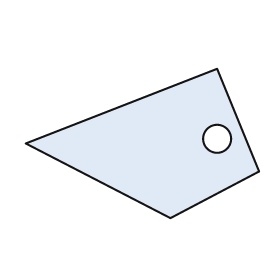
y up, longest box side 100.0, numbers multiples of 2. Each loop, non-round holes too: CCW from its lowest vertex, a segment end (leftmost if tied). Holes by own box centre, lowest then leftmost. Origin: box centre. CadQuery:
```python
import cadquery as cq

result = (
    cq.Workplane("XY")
    .moveTo(12.0, -32.0)
    .lineTo(50.0, -12.0)
    .lineTo(32.0, 32.0)
    .lineTo(-50.0, 0.0)
    .close()
    .moveTo(32.0, 2.0)
    .circle(6.0)
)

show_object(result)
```